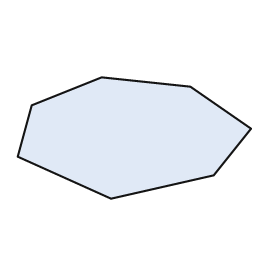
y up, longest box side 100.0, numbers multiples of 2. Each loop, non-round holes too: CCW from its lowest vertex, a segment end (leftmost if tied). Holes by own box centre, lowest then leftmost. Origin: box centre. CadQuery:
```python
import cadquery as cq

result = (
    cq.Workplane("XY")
    .moveTo(-10.0, -26.0)
    .lineTo(34.0, -16.0)
    .lineTo(50.0, 4.0)
    .lineTo(24.0, 22.0)
    .lineTo(-14.0, 26.0)
    .lineTo(-44.0, 14.0)
    .lineTo(-50.0, -8.0)
    .close()
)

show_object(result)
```